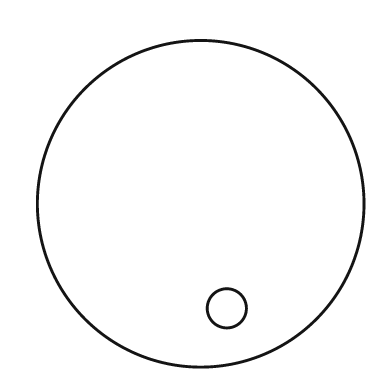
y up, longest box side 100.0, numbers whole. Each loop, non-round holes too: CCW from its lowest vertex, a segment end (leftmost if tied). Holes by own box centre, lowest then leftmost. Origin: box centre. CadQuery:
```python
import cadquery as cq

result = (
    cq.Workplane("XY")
    .moveTo(0.0, 0.0)
    .circle(50.0)
    .moveTo(8.0, -32.0)
    .circle(6.0)
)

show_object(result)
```